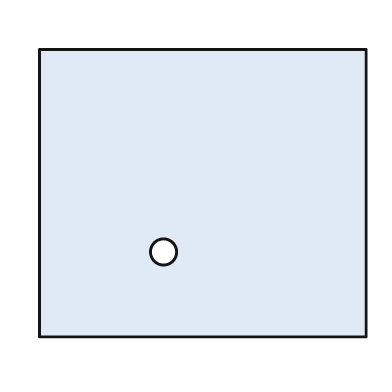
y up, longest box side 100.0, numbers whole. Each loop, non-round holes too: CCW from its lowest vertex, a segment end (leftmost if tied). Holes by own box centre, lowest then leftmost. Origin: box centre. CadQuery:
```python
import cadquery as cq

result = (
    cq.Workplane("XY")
    .moveTo(-50.0, -44.0)
    .lineTo(50.0, -44.0)
    .lineTo(50.0, 44.0)
    .lineTo(-50.0, 44.0)
    .close()
    .moveTo(-12.0, -18.0)
    .circle(4.0)
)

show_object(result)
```